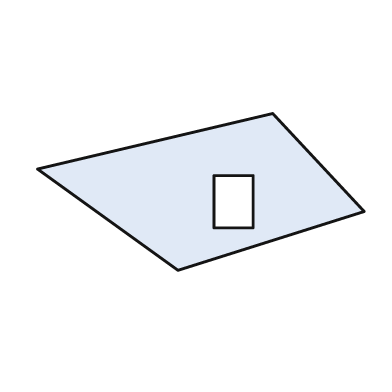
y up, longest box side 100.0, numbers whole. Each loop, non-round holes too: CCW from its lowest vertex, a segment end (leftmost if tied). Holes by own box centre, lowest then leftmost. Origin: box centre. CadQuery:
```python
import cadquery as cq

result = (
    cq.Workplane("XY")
    .moveTo(-7.0, -24.0)
    .lineTo(50.0, -6.0)
    .lineTo(22.0, 24.0)
    .lineTo(-50.0, 7.0)
    .close()
    .moveTo(4.0, -11.0)
    .lineTo(16.0, -11.0)
    .lineTo(16.0, 5.0)
    .lineTo(4.0, 5.0)
    .close()
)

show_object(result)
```